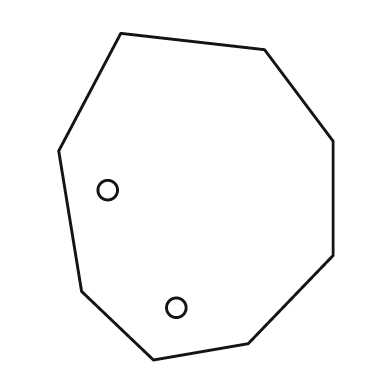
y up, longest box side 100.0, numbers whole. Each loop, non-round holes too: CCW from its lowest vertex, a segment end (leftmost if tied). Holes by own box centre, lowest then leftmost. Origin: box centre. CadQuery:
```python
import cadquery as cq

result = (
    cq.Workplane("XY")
    .moveTo(-13.0, -50.0)
    .lineTo(16.0, -45.0)
    .lineTo(42.0, -18.0)
    .lineTo(42.0, 17.0)
    .lineTo(21.0, 45.0)
    .lineTo(-23.0, 50.0)
    .lineTo(-42.0, 14.0)
    .lineTo(-35.0, -29.0)
    .close()
    .moveTo(-6.0, -34.0)
    .circle(3.0)
    .moveTo(-27.0, 2.0)
    .circle(3.0)
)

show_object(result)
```